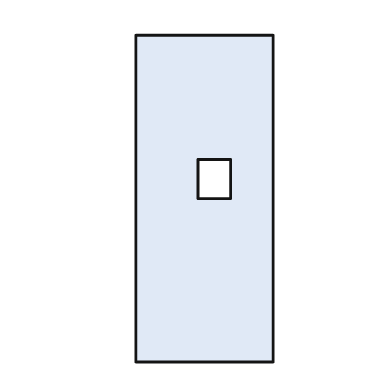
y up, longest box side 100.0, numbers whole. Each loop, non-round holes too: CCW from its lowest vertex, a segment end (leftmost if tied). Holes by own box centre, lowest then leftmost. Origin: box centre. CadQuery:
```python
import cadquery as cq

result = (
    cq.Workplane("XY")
    .moveTo(-21.0, -50.0)
    .lineTo(21.0, -50.0)
    .lineTo(21.0, 50.0)
    .lineTo(-21.0, 50.0)
    .close()
    .moveTo(-2.0, 0.0)
    .lineTo(8.0, 0.0)
    .lineTo(8.0, 12.0)
    .lineTo(-2.0, 12.0)
    .close()
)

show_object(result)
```